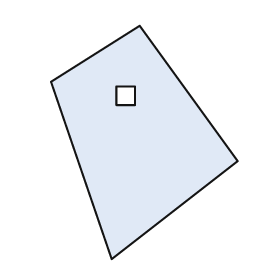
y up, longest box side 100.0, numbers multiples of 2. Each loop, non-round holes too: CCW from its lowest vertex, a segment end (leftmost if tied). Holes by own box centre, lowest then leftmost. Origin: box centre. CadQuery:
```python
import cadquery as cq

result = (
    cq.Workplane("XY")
    .moveTo(-14.0, -50.0)
    .lineTo(40.0, -8.0)
    .lineTo(-2.0, 50.0)
    .lineTo(-40.0, 26.0)
    .close()
    .moveTo(-12.0, 16.0)
    .lineTo(-4.0, 16.0)
    .lineTo(-4.0, 24.0)
    .lineTo(-12.0, 24.0)
    .close()
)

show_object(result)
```